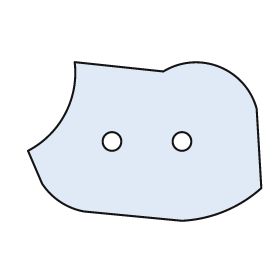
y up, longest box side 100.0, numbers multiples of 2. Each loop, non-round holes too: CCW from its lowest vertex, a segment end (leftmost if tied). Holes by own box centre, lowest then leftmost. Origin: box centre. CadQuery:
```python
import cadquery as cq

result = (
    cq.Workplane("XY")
    .moveTo(16.0, -34.0)
    .threePointArc((34.0, -30.0), (50.0, -20.0))
    .lineTo(48.0, 14.0)
    .threePointArc((32.0, 32.0), (8.0, 30.0))
    .lineTo(-30.0, 34.0)
    .threePointArc((-34.0, 12.0), (-50.0, -4.0))
    .lineTo(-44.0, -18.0)
    .threePointArc((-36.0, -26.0), (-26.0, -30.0))
    .close()
    .moveTo(-14.0, 0.0)
    .circle(4.0)
    .moveTo(16.0, 0.0)
    .circle(4.0)
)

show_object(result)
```